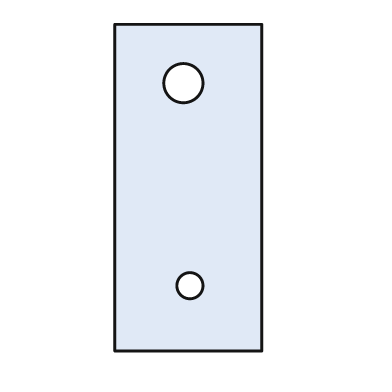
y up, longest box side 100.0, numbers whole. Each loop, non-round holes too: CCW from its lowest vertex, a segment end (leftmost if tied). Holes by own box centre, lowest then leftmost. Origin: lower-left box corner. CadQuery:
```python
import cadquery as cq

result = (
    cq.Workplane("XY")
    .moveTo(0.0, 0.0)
    .lineTo(45.0, 0.0)
    .lineTo(45.0, 100.0)
    .lineTo(0.0, 100.0)
    .close()
    .moveTo(23.0, 20.0)
    .circle(4.0)
    .moveTo(21.0, 82.0)
    .circle(6.0)
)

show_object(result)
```